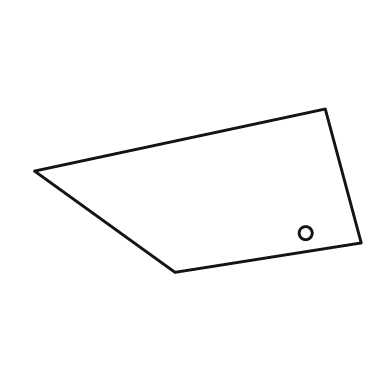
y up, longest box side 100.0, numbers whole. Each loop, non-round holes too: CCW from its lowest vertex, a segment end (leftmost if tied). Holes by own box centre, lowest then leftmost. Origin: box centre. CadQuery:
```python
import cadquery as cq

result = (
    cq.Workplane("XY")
    .moveTo(-7.0, -25.0)
    .lineTo(50.0, -16.0)
    .lineTo(39.0, 25.0)
    .lineTo(-50.0, 6.0)
    .close()
    .moveTo(33.0, -13.0)
    .circle(2.0)
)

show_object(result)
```